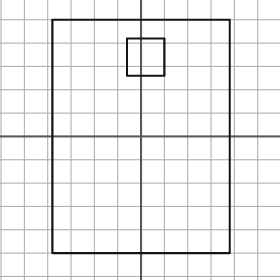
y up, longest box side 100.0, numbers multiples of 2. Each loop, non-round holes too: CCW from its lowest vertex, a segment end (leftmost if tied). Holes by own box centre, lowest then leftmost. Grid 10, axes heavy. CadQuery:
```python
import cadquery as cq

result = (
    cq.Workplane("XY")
    .moveTo(-38.0, -50.0)
    .lineTo(38.0, -50.0)
    .lineTo(38.0, 50.0)
    .lineTo(-38.0, 50.0)
    .close()
    .moveTo(-6.0, 26.0)
    .lineTo(10.0, 26.0)
    .lineTo(10.0, 42.0)
    .lineTo(-6.0, 42.0)
    .close()
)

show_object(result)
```